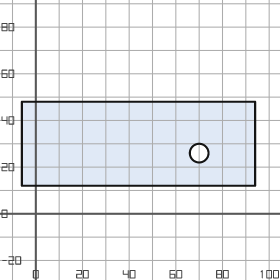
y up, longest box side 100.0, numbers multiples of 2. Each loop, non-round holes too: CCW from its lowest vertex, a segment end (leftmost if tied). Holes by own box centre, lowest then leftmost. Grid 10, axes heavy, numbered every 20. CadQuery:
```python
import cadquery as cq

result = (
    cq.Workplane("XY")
    .moveTo(-6.0, 12.0)
    .lineTo(94.0, 12.0)
    .lineTo(94.0, 48.0)
    .lineTo(-6.0, 48.0)
    .close()
    .moveTo(70.0, 26.0)
    .circle(4.0)
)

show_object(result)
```